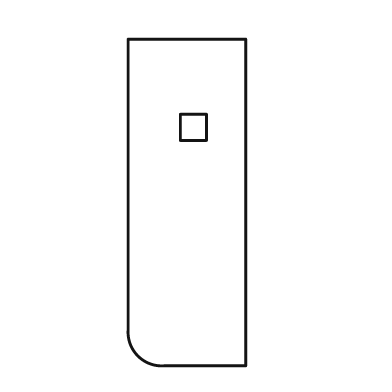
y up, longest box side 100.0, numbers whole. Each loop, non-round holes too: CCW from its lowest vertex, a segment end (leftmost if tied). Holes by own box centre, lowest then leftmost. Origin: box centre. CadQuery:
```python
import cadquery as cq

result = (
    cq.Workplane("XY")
    .moveTo(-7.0, -50.0)
    .lineTo(18.0, -50.0)
    .lineTo(18.0, 50.0)
    .lineTo(-18.0, 50.0)
    .lineTo(-18.0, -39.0)
    .threePointArc((-15.0, -47.0), (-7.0, -50.0))
    .close()
    .moveTo(-2.0, 19.0)
    .lineTo(6.0, 19.0)
    .lineTo(6.0, 27.0)
    .lineTo(-2.0, 27.0)
    .close()
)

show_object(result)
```